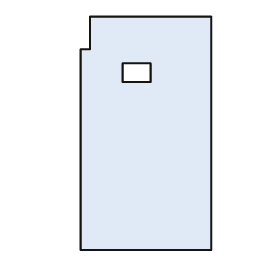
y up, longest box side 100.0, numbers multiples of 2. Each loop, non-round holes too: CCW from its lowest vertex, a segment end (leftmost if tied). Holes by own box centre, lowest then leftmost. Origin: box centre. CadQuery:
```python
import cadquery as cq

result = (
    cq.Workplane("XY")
    .moveTo(-28.0, -50.0)
    .lineTo(28.0, -50.0)
    .lineTo(28.0, 50.0)
    .lineTo(-24.0, 50.0)
    .lineTo(-24.0, 36.0)
    .lineTo(-28.0, 36.0)
    .close()
    .moveTo(-10.0, 22.0)
    .lineTo(2.0, 22.0)
    .lineTo(2.0, 30.0)
    .lineTo(-10.0, 30.0)
    .close()
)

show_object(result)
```